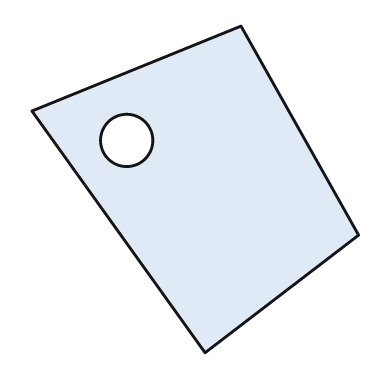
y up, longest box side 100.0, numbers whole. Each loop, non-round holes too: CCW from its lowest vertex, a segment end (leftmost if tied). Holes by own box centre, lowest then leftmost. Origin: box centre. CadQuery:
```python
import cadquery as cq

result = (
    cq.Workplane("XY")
    .moveTo(3.0, -50.0)
    .lineTo(50.0, -14.0)
    .lineTo(14.0, 50.0)
    .lineTo(-50.0, 24.0)
    .close()
    .moveTo(-21.0, 15.0)
    .circle(8.0)
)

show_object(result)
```